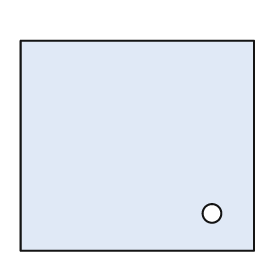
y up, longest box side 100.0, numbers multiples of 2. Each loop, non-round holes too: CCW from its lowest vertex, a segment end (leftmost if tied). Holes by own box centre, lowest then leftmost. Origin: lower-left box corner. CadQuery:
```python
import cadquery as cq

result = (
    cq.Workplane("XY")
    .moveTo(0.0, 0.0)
    .lineTo(100.0, 0.0)
    .lineTo(100.0, 90.0)
    .lineTo(0.0, 90.0)
    .close()
    .moveTo(82.0, 16.0)
    .circle(4.0)
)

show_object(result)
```